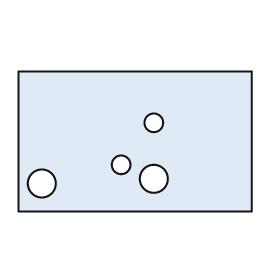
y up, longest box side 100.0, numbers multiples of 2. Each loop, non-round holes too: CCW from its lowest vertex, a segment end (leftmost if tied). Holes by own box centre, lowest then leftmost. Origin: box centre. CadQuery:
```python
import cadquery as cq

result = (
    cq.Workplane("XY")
    .moveTo(-50.0, -30.0)
    .lineTo(50.0, -30.0)
    .lineTo(50.0, 30.0)
    .lineTo(-50.0, 30.0)
    .close()
    .moveTo(-40.0, -18.0)
    .circle(6.0)
    .moveTo(8.0, -16.0)
    .circle(6.0)
    .moveTo(-6.0, -10.0)
    .circle(4.0)
    .moveTo(8.0, 8.0)
    .circle(4.0)
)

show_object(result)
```